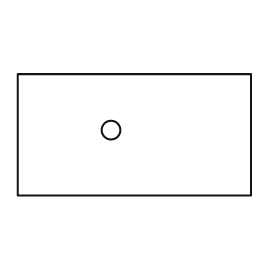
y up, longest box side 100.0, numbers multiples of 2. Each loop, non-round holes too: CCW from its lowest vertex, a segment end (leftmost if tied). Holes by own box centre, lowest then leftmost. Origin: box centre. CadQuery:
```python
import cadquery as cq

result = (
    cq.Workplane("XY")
    .moveTo(-50.0, -26.0)
    .lineTo(50.0, -26.0)
    .lineTo(50.0, 26.0)
    .lineTo(-50.0, 26.0)
    .close()
    .moveTo(-10.0, 2.0)
    .circle(4.0)
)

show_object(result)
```